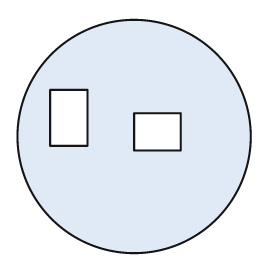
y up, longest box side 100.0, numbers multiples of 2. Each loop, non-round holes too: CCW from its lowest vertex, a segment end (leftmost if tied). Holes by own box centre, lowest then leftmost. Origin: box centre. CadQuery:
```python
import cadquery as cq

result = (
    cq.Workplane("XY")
    .moveTo(0.0, 0.0)
    .circle(50.0)
    .moveTo(0.0, -6.0)
    .lineTo(20.0, -6.0)
    .lineTo(20.0, 10.0)
    .lineTo(0.0, 10.0)
    .close()
    .moveTo(-36.0, -4.0)
    .lineTo(-20.0, -4.0)
    .lineTo(-20.0, 20.0)
    .lineTo(-36.0, 20.0)
    .close()
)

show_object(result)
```